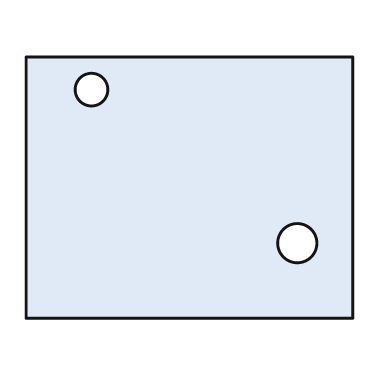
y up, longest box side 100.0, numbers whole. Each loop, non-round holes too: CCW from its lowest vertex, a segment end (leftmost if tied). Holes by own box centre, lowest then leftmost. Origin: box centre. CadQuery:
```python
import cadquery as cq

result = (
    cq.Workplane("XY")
    .moveTo(-50.0, -40.0)
    .lineTo(50.0, -40.0)
    .lineTo(50.0, 40.0)
    .lineTo(-50.0, 40.0)
    .close()
    .moveTo(33.0, -17.0)
    .circle(6.0)
    .moveTo(-30.0, 30.0)
    .circle(5.0)
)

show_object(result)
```